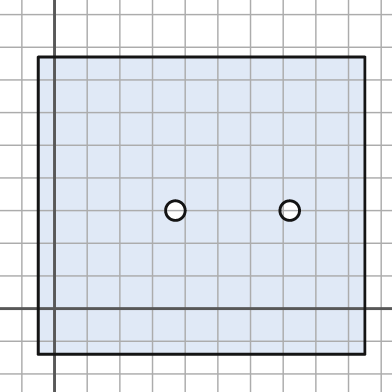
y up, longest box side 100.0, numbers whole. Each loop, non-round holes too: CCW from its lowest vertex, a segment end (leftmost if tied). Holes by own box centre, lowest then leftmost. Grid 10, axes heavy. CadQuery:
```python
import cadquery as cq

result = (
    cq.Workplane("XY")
    .moveTo(-5.0, -14.0)
    .lineTo(95.0, -14.0)
    .lineTo(95.0, 77.0)
    .lineTo(-5.0, 77.0)
    .close()
    .moveTo(37.0, 30.0)
    .circle(3.0)
    .moveTo(72.0, 30.0)
    .circle(3.0)
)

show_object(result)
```